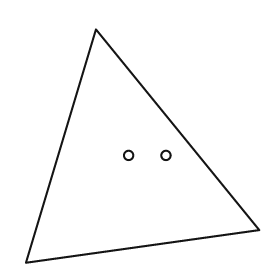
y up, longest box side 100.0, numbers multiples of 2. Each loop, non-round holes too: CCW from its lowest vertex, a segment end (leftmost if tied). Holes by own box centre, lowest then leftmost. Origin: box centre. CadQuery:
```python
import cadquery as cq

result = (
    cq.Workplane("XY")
    .moveTo(-50.0, -50.0)
    .lineTo(50.0, -36.0)
    .lineTo(-20.0, 50.0)
    .close()
    .moveTo(-6.0, -4.0)
    .circle(2.0)
    .moveTo(10.0, -4.0)
    .circle(2.0)
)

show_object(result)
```